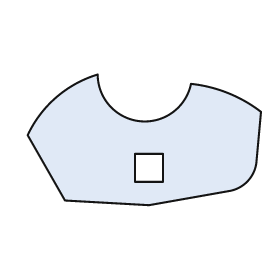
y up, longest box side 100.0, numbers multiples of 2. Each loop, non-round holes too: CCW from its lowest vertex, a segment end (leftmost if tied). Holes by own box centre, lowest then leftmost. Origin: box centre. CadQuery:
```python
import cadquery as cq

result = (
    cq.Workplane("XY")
    .moveTo(2.0, -28.0)
    .lineTo(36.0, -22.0)
    .threePointArc((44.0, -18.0), (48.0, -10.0))
    .lineTo(50.0, 12.0)
    .threePointArc((36.0, 20.0), (20.0, 24.0))
    .threePointArc((-2.0, 8.0), (-20.0, 28.0))
    .threePointArc((-38.0, 18.0), (-50.0, 2.0))
    .lineTo(-34.0, -26.0)
    .close()
    .moveTo(-4.0, -18.0)
    .lineTo(8.0, -18.0)
    .lineTo(8.0, -6.0)
    .lineTo(-4.0, -6.0)
    .close()
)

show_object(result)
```